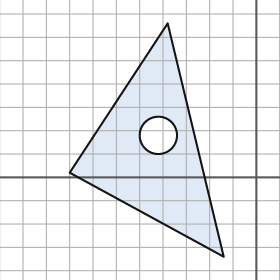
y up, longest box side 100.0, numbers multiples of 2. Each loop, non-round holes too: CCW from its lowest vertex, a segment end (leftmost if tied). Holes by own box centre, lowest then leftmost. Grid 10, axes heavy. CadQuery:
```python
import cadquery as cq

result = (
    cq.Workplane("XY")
    .moveTo(-14.0, -34.0)
    .lineTo(-38.0, 66.0)
    .lineTo(-80.0, 2.0)
    .close()
    .moveTo(-42.0, 18.0)
    .circle(8.0)
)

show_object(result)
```